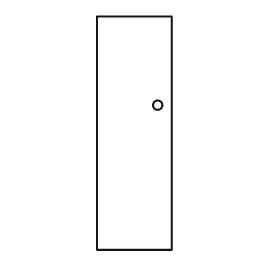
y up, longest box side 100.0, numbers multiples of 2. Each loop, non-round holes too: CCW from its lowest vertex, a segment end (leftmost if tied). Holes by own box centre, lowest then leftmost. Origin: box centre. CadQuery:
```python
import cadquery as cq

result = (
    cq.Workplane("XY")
    .moveTo(-16.0, -50.0)
    .lineTo(16.0, -50.0)
    .lineTo(16.0, 50.0)
    .lineTo(-16.0, 50.0)
    .close()
    .moveTo(10.0, 12.0)
    .circle(2.0)
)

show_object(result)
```